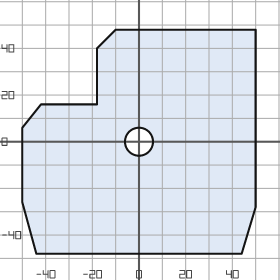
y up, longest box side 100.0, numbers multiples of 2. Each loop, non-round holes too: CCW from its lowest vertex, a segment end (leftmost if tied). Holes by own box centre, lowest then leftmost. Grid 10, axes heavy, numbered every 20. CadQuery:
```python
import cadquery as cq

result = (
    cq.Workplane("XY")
    .moveTo(-44.0, -48.0)
    .lineTo(44.0, -48.0)
    .lineTo(50.0, -28.0)
    .lineTo(50.0, 48.0)
    .lineTo(-10.0, 48.0)
    .lineTo(-18.0, 40.0)
    .lineTo(-18.0, 16.0)
    .lineTo(-42.0, 16.0)
    .lineTo(-50.0, 6.0)
    .lineTo(-50.0, -26.0)
    .close()
    .moveTo(0.0, 0.0)
    .circle(6.0)
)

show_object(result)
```